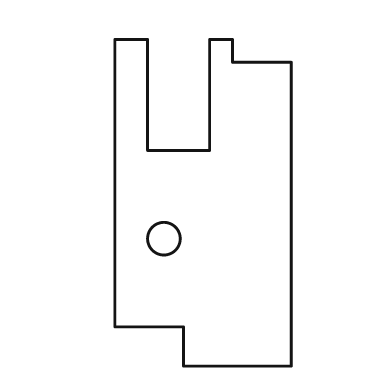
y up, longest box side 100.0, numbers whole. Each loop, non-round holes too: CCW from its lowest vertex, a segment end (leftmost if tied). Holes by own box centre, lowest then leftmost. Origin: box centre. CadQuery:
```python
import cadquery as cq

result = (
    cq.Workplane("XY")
    .moveTo(-6.0, -50.0)
    .lineTo(27.0, -50.0)
    .lineTo(27.0, 43.0)
    .lineTo(9.0, 43.0)
    .lineTo(9.0, 50.0)
    .lineTo(2.0, 50.0)
    .lineTo(2.0, 16.0)
    .lineTo(-17.0, 16.0)
    .lineTo(-17.0, 50.0)
    .lineTo(-27.0, 50.0)
    .lineTo(-27.0, -38.0)
    .lineTo(-6.0, -38.0)
    .close()
    .moveTo(-12.0, -11.0)
    .circle(5.0)
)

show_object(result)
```